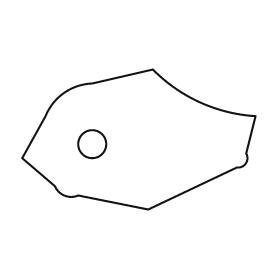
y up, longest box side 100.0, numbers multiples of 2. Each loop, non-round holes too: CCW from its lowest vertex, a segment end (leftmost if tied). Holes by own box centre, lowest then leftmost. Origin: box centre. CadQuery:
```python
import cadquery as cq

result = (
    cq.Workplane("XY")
    .moveTo(4.0, -30.0)
    .lineTo(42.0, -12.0)
    .threePointArc((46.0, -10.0), (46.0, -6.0))
    .lineTo(50.0, 10.0)
    .threePointArc((26.0, 16.0), (6.0, 30.0))
    .lineTo(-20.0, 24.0)
    .threePointArc((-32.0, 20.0), (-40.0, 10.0))
    .lineTo(-50.0, -8.0)
    .lineTo(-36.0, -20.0)
    .threePointArc((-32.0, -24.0), (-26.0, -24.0))
    .close()
    .moveTo(-20.0, -2.0)
    .circle(6.0)
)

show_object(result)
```